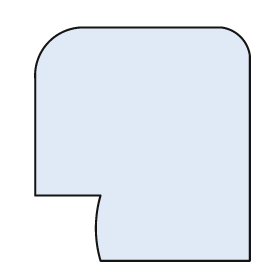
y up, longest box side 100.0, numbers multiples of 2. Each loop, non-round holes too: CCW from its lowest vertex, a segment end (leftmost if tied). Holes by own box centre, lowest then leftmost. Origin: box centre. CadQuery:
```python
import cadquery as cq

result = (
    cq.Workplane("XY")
    .moveTo(-18.0, -50.0)
    .lineTo(46.0, -50.0)
    .lineTo(46.0, 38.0)
    .threePointArc((42.0, 46.0), (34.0, 50.0))
    .lineTo(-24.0, 50.0)
    .threePointArc((-40.0, 44.0), (-46.0, 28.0))
    .lineTo(-46.0, -22.0)
    .lineTo(-18.0, -22.0)
    .threePointArc((-20.0, -36.0), (-18.0, -50.0))
    .close()
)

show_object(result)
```